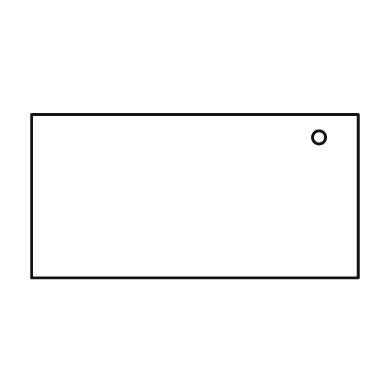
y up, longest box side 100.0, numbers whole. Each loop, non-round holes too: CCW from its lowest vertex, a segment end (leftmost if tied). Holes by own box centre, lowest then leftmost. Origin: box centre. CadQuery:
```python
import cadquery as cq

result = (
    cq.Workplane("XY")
    .moveTo(-50.0, -25.0)
    .lineTo(50.0, -25.0)
    .lineTo(50.0, 25.0)
    .lineTo(-50.0, 25.0)
    .close()
    .moveTo(38.0, 18.0)
    .circle(2.0)
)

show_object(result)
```